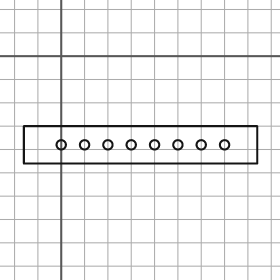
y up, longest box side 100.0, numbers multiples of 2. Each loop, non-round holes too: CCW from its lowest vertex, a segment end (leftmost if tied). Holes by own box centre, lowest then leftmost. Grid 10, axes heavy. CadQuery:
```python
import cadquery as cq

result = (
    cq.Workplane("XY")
    .moveTo(-16.0, -46.0)
    .lineTo(84.0, -46.0)
    .lineTo(84.0, -30.0)
    .lineTo(-16.0, -30.0)
    .close()
    .moveTo(0.0, -38.0)
    .circle(2.0)
    .moveTo(10.0, -38.0)
    .circle(2.0)
    .moveTo(20.0, -38.0)
    .circle(2.0)
    .moveTo(30.0, -38.0)
    .circle(2.0)
    .moveTo(40.0, -38.0)
    .circle(2.0)
    .moveTo(50.0, -38.0)
    .circle(2.0)
    .moveTo(60.0, -38.0)
    .circle(2.0)
    .moveTo(70.0, -38.0)
    .circle(2.0)
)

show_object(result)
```